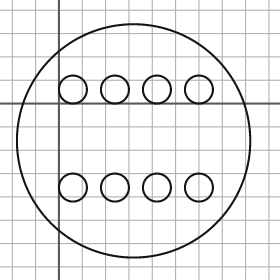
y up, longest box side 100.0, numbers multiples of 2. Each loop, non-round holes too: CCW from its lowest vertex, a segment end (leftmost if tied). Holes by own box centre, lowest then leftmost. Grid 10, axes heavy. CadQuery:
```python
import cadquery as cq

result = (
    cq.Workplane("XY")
    .moveTo(32.0, -16.0)
    .circle(50.0)
    .moveTo(6.0, -36.0)
    .circle(6.0)
    .moveTo(24.0, -36.0)
    .circle(6.0)
    .moveTo(42.0, -36.0)
    .circle(6.0)
    .moveTo(60.0, -36.0)
    .circle(6.0)
    .moveTo(6.0, 6.0)
    .circle(6.0)
    .moveTo(24.0, 6.0)
    .circle(6.0)
    .moveTo(42.0, 6.0)
    .circle(6.0)
    .moveTo(60.0, 6.0)
    .circle(6.0)
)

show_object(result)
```